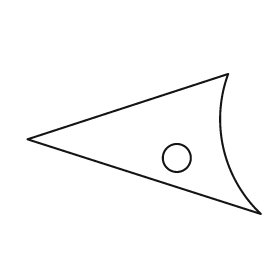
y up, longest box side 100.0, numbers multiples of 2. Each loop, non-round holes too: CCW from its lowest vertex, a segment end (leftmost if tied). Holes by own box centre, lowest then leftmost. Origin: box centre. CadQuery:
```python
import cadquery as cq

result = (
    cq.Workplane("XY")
    .moveTo(50.0, -30.0)
    .threePointArc((34.0, -2.0), (36.0, 30.0))
    .lineTo(-50.0, 2.0)
    .close()
    .moveTo(14.0, -6.0)
    .circle(6.0)
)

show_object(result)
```